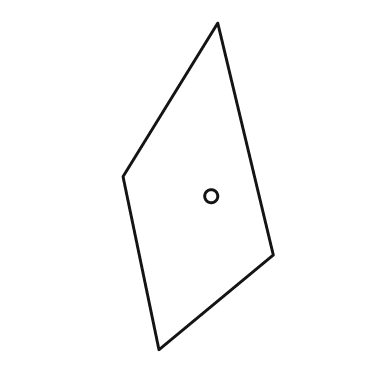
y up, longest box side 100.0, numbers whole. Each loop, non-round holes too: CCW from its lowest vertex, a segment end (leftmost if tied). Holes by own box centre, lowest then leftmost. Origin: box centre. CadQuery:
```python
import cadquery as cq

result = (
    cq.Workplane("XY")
    .moveTo(-12.0, -50.0)
    .lineTo(23.0, -21.0)
    .lineTo(6.0, 50.0)
    .lineTo(-23.0, 3.0)
    .close()
    .moveTo(4.0, -3.0)
    .circle(2.0)
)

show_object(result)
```